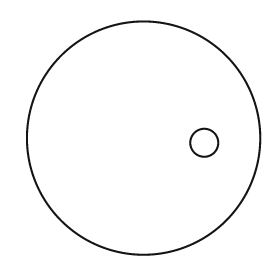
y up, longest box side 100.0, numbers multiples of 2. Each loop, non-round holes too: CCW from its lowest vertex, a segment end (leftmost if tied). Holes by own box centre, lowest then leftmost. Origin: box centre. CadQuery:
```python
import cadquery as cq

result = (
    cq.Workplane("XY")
    .moveTo(0.0, 0.0)
    .circle(50.0)
    .moveTo(26.0, -2.0)
    .circle(6.0)
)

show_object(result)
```